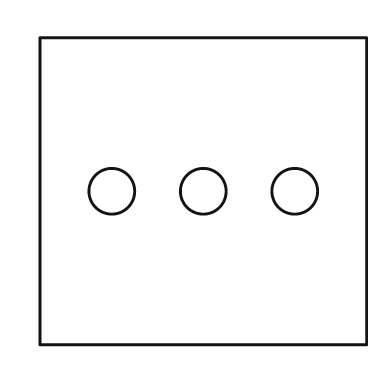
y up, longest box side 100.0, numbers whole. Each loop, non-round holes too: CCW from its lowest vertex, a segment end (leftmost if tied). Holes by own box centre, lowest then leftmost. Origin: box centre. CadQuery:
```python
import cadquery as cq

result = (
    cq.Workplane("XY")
    .moveTo(-50.0, -47.0)
    .lineTo(50.0, -47.0)
    .lineTo(50.0, 47.0)
    .lineTo(-50.0, 47.0)
    .close()
    .moveTo(-28.0, 0.0)
    .circle(7.0)
    .moveTo(0.0, 0.0)
    .circle(7.0)
    .moveTo(28.0, 0.0)
    .circle(7.0)
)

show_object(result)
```